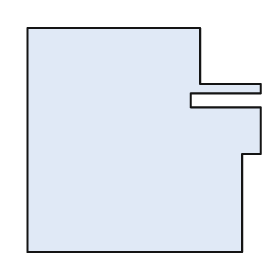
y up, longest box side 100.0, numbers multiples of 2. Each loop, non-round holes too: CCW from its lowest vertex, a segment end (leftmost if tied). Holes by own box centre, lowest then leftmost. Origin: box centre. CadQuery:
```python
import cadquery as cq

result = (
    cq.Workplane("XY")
    .moveTo(-50.0, -48.0)
    .lineTo(42.0, -48.0)
    .lineTo(42.0, -6.0)
    .lineTo(50.0, -6.0)
    .lineTo(50.0, 14.0)
    .lineTo(20.0, 14.0)
    .lineTo(20.0, 20.0)
    .lineTo(50.0, 20.0)
    .lineTo(50.0, 24.0)
    .lineTo(24.0, 24.0)
    .lineTo(24.0, 48.0)
    .lineTo(-50.0, 48.0)
    .close()
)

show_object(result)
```